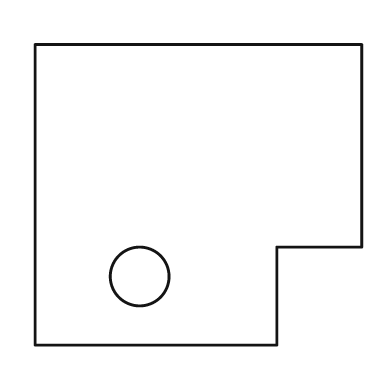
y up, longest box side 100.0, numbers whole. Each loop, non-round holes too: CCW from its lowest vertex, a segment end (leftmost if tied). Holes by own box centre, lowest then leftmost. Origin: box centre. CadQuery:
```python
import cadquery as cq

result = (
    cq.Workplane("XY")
    .moveTo(-50.0, -46.0)
    .lineTo(24.0, -46.0)
    .lineTo(24.0, -16.0)
    .lineTo(50.0, -16.0)
    .lineTo(50.0, 46.0)
    .lineTo(-50.0, 46.0)
    .close()
    .moveTo(-18.0, -25.0)
    .circle(9.0)
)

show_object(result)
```